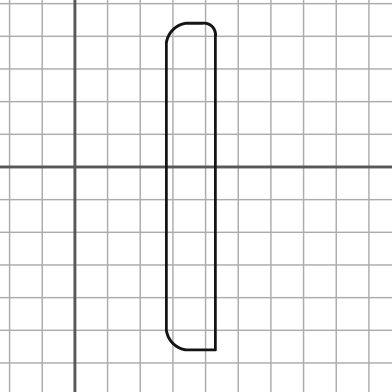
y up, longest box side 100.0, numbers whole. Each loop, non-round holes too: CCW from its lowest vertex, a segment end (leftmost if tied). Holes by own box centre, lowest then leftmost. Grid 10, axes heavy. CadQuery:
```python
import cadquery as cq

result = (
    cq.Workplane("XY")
    .moveTo(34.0, -56.0)
    .lineTo(43.0, -56.0)
    .lineTo(43.0, 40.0)
    .threePointArc((42.0, 43.0), (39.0, 44.0))
    .lineTo(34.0, 44.0)
    .threePointArc((30.0, 42.0), (28.0, 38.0))
    .lineTo(28.0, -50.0)
    .threePointArc((30.0, -54.0), (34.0, -56.0))
    .close()
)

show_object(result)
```